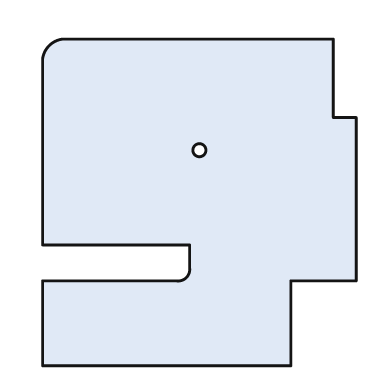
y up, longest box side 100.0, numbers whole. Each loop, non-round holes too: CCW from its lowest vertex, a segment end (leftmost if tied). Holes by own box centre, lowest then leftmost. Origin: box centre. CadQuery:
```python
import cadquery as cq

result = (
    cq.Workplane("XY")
    .moveTo(-48.0, -50.0)
    .lineTo(28.0, -50.0)
    .lineTo(28.0, -24.0)
    .lineTo(48.0, -24.0)
    .lineTo(48.0, 26.0)
    .lineTo(41.0, 26.0)
    .lineTo(41.0, 50.0)
    .lineTo(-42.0, 50.0)
    .threePointArc((-46.0, 48.0), (-48.0, 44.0))
    .lineTo(-48.0, -13.0)
    .lineTo(-3.0, -13.0)
    .lineTo(-3.0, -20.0)
    .threePointArc((-4.0, -23.0), (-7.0, -24.0))
    .lineTo(-48.0, -24.0)
    .close()
    .moveTo(0.0, 16.0)
    .circle(2.0)
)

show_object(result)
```